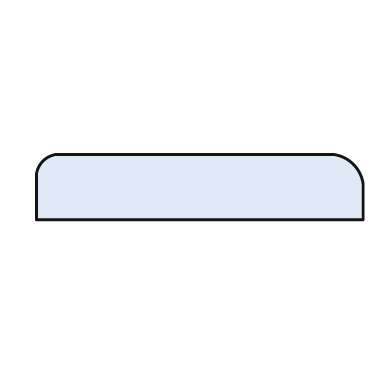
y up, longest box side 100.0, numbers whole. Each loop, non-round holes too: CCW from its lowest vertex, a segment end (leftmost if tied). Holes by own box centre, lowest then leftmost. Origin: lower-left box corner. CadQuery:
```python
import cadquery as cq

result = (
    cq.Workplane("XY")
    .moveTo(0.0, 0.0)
    .lineTo(100.0, 0.0)
    .lineTo(100.0, 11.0)
    .threePointArc((97.0, 17.0), (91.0, 20.0))
    .lineTo(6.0, 20.0)
    .threePointArc((2.0, 18.0), (0.0, 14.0))
    .close()
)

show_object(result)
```